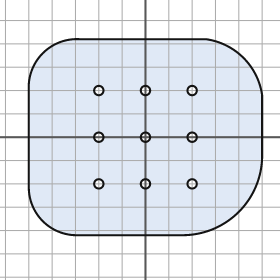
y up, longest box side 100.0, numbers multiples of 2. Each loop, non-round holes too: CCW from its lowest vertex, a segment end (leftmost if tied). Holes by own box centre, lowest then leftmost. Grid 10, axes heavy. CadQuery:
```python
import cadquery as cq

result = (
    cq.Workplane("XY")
    .moveTo(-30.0, -42.0)
    .lineTo(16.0, -42.0)
    .threePointArc((40.0, -32.0), (50.0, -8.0))
    .lineTo(50.0, 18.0)
    .threePointArc((42.0, 34.0), (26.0, 42.0))
    .lineTo(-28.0, 42.0)
    .threePointArc((-44.0, 36.0), (-50.0, 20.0))
    .lineTo(-50.0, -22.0)
    .threePointArc((-44.0, -36.0), (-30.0, -42.0))
    .close()
    .moveTo(-20.0, -20.0)
    .circle(2.0)
    .moveTo(0.0, -20.0)
    .circle(2.0)
    .moveTo(20.0, -20.0)
    .circle(2.0)
    .moveTo(-20.0, 0.0)
    .circle(2.0)
    .moveTo(0.0, 0.0)
    .circle(2.0)
    .moveTo(20.0, 0.0)
    .circle(2.0)
    .moveTo(-20.0, 20.0)
    .circle(2.0)
    .moveTo(0.0, 20.0)
    .circle(2.0)
    .moveTo(20.0, 20.0)
    .circle(2.0)
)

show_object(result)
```